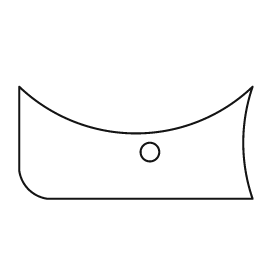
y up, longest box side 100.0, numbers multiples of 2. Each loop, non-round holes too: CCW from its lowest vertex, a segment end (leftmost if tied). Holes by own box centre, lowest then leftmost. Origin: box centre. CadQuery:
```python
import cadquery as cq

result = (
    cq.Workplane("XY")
    .moveTo(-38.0, -24.0)
    .lineTo(50.0, -24.0)
    .threePointArc((46.0, 0.0), (50.0, 24.0))
    .threePointArc((0.0, 4.0), (-50.0, 24.0))
    .lineTo(-50.0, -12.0)
    .threePointArc((-46.0, -20.0), (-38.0, -24.0))
    .close()
    .moveTo(6.0, -4.0)
    .circle(4.0)
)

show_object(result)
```